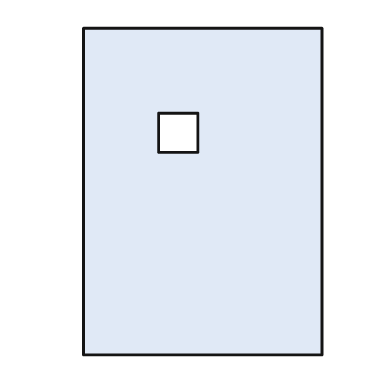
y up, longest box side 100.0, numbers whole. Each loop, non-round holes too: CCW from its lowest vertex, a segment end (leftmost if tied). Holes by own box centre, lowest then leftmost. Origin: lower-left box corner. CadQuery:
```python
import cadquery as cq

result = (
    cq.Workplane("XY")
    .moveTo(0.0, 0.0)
    .lineTo(73.0, 0.0)
    .lineTo(73.0, 100.0)
    .lineTo(0.0, 100.0)
    .close()
    .moveTo(23.0, 62.0)
    .lineTo(35.0, 62.0)
    .lineTo(35.0, 74.0)
    .lineTo(23.0, 74.0)
    .close()
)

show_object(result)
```